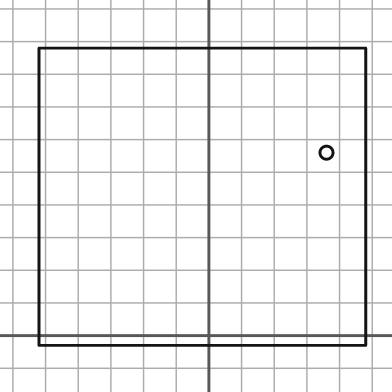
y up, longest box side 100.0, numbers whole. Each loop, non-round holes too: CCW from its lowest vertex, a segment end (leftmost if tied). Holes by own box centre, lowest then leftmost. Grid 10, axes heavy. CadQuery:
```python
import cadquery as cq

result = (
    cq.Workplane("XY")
    .moveTo(-52.0, -3.0)
    .lineTo(48.0, -3.0)
    .lineTo(48.0, 88.0)
    .lineTo(-52.0, 88.0)
    .close()
    .moveTo(36.0, 56.0)
    .circle(2.0)
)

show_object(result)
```